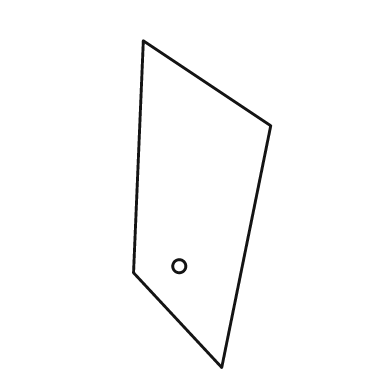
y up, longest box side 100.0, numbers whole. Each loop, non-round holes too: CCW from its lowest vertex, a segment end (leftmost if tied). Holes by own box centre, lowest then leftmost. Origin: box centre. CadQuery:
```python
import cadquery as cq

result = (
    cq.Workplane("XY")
    .moveTo(6.0, -50.0)
    .lineTo(21.0, 24.0)
    .lineTo(-18.0, 50.0)
    .lineTo(-21.0, -21.0)
    .close()
    .moveTo(-7.0, -19.0)
    .circle(2.0)
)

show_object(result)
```